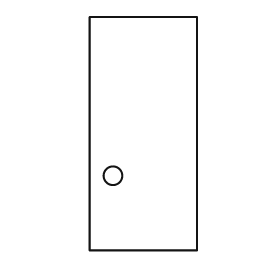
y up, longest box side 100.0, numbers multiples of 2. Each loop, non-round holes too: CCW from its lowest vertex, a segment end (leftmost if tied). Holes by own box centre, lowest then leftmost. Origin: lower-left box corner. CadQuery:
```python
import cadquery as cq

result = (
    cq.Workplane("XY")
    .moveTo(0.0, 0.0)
    .lineTo(46.0, 0.0)
    .lineTo(46.0, 100.0)
    .lineTo(0.0, 100.0)
    .close()
    .moveTo(10.0, 32.0)
    .circle(4.0)
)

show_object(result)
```